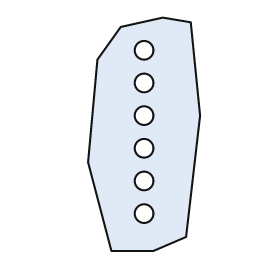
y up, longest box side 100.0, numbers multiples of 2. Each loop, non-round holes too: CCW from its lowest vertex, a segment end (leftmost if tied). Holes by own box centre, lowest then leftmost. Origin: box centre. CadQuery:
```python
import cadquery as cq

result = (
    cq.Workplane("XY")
    .moveTo(-14.0, -50.0)
    .lineTo(4.0, -50.0)
    .lineTo(18.0, -44.0)
    .lineTo(24.0, 8.0)
    .lineTo(20.0, 48.0)
    .lineTo(8.0, 50.0)
    .lineTo(-10.0, 46.0)
    .lineTo(-20.0, 32.0)
    .lineTo(-24.0, -12.0)
    .close()
    .moveTo(0.0, -34.0)
    .circle(4.0)
    .moveTo(0.0, -20.0)
    .circle(4.0)
    .moveTo(0.0, -6.0)
    .circle(4.0)
    .moveTo(0.0, 8.0)
    .circle(4.0)
    .moveTo(0.0, 22.0)
    .circle(4.0)
    .moveTo(0.0, 36.0)
    .circle(4.0)
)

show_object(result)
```